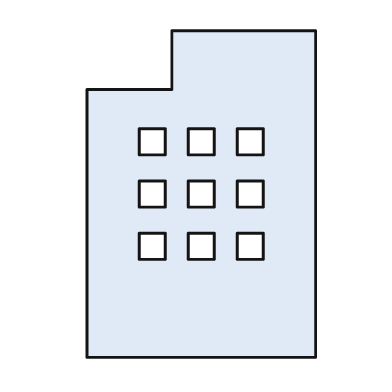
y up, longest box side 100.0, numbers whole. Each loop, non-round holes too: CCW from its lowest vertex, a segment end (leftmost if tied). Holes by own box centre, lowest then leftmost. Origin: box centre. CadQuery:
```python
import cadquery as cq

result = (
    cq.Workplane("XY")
    .moveTo(-35.0, -50.0)
    .lineTo(35.0, -50.0)
    .lineTo(35.0, 50.0)
    .lineTo(-9.0, 50.0)
    .lineTo(-9.0, 32.0)
    .lineTo(-35.0, 32.0)
    .close()
    .moveTo(-19.0, -20.0)
    .lineTo(-11.0, -20.0)
    .lineTo(-11.0, -12.0)
    .lineTo(-19.0, -12.0)
    .close()
    .moveTo(-4.0, -20.0)
    .lineTo(4.0, -20.0)
    .lineTo(4.0, -12.0)
    .lineTo(-4.0, -12.0)
    .close()
    .moveTo(11.0, -20.0)
    .lineTo(19.0, -20.0)
    .lineTo(19.0, -12.0)
    .lineTo(11.0, -12.0)
    .close()
    .moveTo(-19.0, -4.0)
    .lineTo(-11.0, -4.0)
    .lineTo(-11.0, 4.0)
    .lineTo(-19.0, 4.0)
    .close()
    .moveTo(-4.0, -4.0)
    .lineTo(4.0, -4.0)
    .lineTo(4.0, 4.0)
    .lineTo(-4.0, 4.0)
    .close()
    .moveTo(11.0, -4.0)
    .lineTo(19.0, -4.0)
    .lineTo(19.0, 4.0)
    .lineTo(11.0, 4.0)
    .close()
    .moveTo(-19.0, 12.0)
    .lineTo(-11.0, 12.0)
    .lineTo(-11.0, 20.0)
    .lineTo(-19.0, 20.0)
    .close()
    .moveTo(-4.0, 12.0)
    .lineTo(4.0, 12.0)
    .lineTo(4.0, 20.0)
    .lineTo(-4.0, 20.0)
    .close()
    .moveTo(11.0, 12.0)
    .lineTo(19.0, 12.0)
    .lineTo(19.0, 20.0)
    .lineTo(11.0, 20.0)
    .close()
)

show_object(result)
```